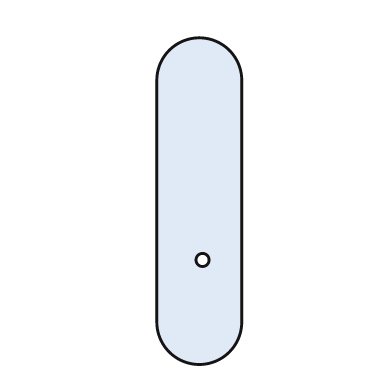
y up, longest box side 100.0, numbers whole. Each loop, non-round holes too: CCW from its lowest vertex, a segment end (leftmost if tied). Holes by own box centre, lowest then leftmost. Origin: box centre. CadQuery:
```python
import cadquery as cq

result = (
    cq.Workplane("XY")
    .moveTo(-13.0, -37.0)
    .threePointArc((0.0, -50.0), (13.0, -37.0))
    .lineTo(13.0, 37.0)
    .threePointArc((0.0, 50.0), (-13.0, 37.0))
    .close()
    .moveTo(1.0, -18.0)
    .circle(2.0)
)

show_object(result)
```